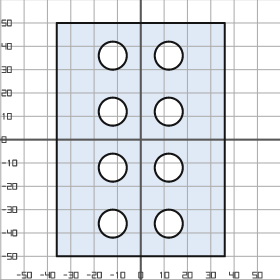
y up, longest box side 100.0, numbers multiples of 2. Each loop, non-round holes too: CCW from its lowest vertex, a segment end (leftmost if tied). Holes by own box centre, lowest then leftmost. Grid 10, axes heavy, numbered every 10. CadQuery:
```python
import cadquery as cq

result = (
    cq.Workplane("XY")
    .moveTo(-36.0, -50.0)
    .lineTo(36.0, -50.0)
    .lineTo(36.0, 50.0)
    .lineTo(-36.0, 50.0)
    .close()
    .moveTo(-12.0, -36.0)
    .circle(6.0)
    .moveTo(12.0, -36.0)
    .circle(6.0)
    .moveTo(-12.0, -12.0)
    .circle(6.0)
    .moveTo(12.0, -12.0)
    .circle(6.0)
    .moveTo(-12.0, 12.0)
    .circle(6.0)
    .moveTo(12.0, 12.0)
    .circle(6.0)
    .moveTo(-12.0, 36.0)
    .circle(6.0)
    .moveTo(12.0, 36.0)
    .circle(6.0)
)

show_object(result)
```